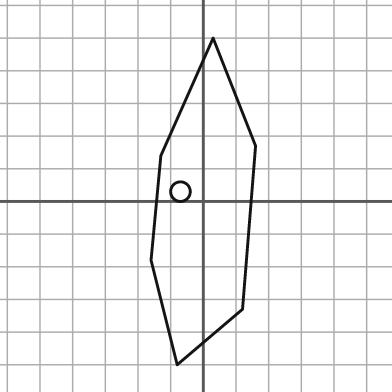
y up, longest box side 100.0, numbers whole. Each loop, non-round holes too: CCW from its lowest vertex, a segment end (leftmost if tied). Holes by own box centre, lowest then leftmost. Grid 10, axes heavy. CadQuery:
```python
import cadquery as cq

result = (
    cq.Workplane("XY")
    .moveTo(-8.0, -50.0)
    .lineTo(12.0, -33.0)
    .lineTo(16.0, 17.0)
    .lineTo(3.0, 50.0)
    .lineTo(-13.0, 14.0)
    .lineTo(-16.0, -18.0)
    .close()
    .moveTo(-7.0, 3.0)
    .circle(3.0)
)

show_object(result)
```